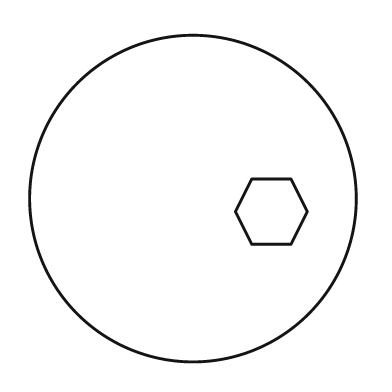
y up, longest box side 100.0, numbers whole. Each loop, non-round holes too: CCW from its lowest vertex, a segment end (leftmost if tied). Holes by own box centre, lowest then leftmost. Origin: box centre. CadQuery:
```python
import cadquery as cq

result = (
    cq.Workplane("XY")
    .moveTo(0.0, 0.0)
    .circle(50.0)
    .moveTo(18.0, -14.0)
    .lineTo(30.0, -14.0)
    .lineTo(35.0, -4.0)
    .lineTo(30.0, 6.0)
    .lineTo(18.0, 6.0)
    .lineTo(13.0, -4.0)
    .close()
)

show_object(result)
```